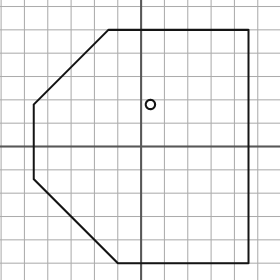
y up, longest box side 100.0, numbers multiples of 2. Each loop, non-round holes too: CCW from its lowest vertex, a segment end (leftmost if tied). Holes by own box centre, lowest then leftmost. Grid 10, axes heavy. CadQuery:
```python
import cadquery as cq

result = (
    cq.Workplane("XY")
    .moveTo(-10.0, -50.0)
    .lineTo(46.0, -50.0)
    .lineTo(46.0, 50.0)
    .lineTo(-14.0, 50.0)
    .lineTo(-46.0, 18.0)
    .lineTo(-46.0, -14.0)
    .close()
    .moveTo(4.0, 18.0)
    .circle(2.0)
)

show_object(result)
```